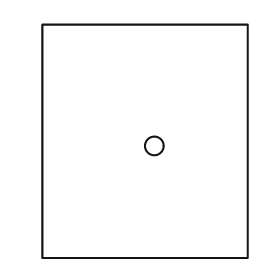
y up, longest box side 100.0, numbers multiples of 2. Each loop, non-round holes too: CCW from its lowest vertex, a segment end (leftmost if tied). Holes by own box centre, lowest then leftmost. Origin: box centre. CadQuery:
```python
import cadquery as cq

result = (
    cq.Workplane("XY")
    .moveTo(-44.0, -50.0)
    .lineTo(44.0, -50.0)
    .lineTo(44.0, 50.0)
    .lineTo(-44.0, 50.0)
    .close()
    .moveTo(4.0, -2.0)
    .circle(4.0)
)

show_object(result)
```